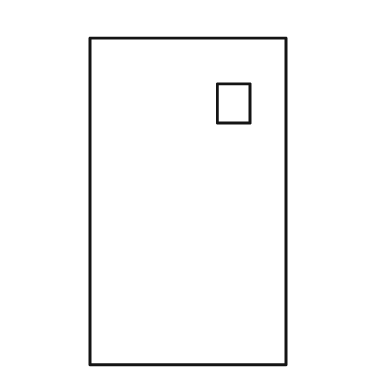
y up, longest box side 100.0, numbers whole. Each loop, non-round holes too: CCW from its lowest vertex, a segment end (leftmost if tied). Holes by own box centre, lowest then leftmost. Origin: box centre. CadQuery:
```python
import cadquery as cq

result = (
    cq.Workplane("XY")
    .moveTo(-30.0, -50.0)
    .lineTo(30.0, -50.0)
    .lineTo(30.0, 50.0)
    .lineTo(-30.0, 50.0)
    .close()
    .moveTo(9.0, 24.0)
    .lineTo(19.0, 24.0)
    .lineTo(19.0, 36.0)
    .lineTo(9.0, 36.0)
    .close()
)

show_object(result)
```